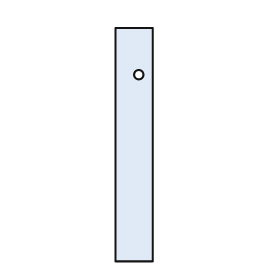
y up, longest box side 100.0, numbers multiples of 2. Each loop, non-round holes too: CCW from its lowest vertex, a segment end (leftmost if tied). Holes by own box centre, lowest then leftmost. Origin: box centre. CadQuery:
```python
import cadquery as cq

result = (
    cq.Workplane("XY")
    .moveTo(-8.0, -50.0)
    .lineTo(8.0, -50.0)
    .lineTo(8.0, 50.0)
    .lineTo(-8.0, 50.0)
    .close()
    .moveTo(2.0, 30.0)
    .circle(2.0)
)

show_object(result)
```